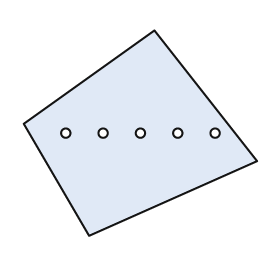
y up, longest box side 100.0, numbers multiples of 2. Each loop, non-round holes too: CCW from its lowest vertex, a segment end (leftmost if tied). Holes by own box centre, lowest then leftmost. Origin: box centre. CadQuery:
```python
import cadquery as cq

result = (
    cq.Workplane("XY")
    .moveTo(-22.0, -44.0)
    .lineTo(50.0, -12.0)
    .lineTo(6.0, 44.0)
    .lineTo(-50.0, 4.0)
    .close()
    .moveTo(-32.0, 0.0)
    .circle(2.0)
    .moveTo(-16.0, 0.0)
    .circle(2.0)
    .moveTo(0.0, 0.0)
    .circle(2.0)
    .moveTo(16.0, 0.0)
    .circle(2.0)
    .moveTo(32.0, 0.0)
    .circle(2.0)
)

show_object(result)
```